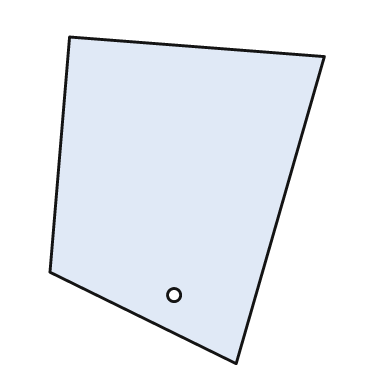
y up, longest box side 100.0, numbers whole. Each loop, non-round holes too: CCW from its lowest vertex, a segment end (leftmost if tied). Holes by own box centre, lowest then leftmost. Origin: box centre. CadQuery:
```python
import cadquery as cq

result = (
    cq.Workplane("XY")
    .moveTo(15.0, -50.0)
    .lineTo(42.0, 44.0)
    .lineTo(-36.0, 50.0)
    .lineTo(-42.0, -22.0)
    .close()
    .moveTo(-4.0, -29.0)
    .circle(2.0)
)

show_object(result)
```